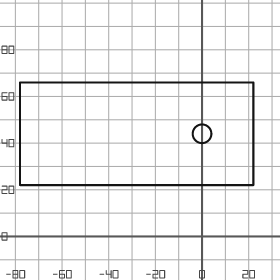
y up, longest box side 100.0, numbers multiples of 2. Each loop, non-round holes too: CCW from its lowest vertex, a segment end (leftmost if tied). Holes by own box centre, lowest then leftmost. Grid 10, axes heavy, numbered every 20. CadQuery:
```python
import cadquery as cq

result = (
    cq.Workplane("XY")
    .moveTo(-78.0, 22.0)
    .lineTo(22.0, 22.0)
    .lineTo(22.0, 66.0)
    .lineTo(-78.0, 66.0)
    .close()
    .moveTo(0.0, 44.0)
    .circle(4.0)
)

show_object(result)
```